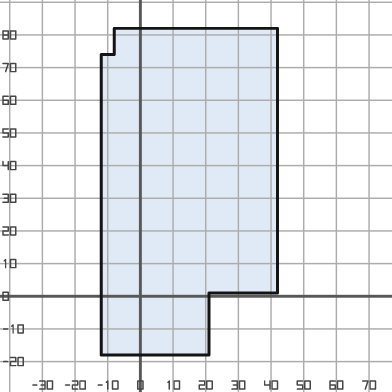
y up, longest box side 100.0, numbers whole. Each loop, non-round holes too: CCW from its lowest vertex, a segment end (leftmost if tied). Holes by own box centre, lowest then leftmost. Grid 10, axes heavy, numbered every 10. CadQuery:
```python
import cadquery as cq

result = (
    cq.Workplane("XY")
    .moveTo(-12.0, -18.0)
    .lineTo(21.0, -18.0)
    .lineTo(21.0, 1.0)
    .lineTo(42.0, 1.0)
    .lineTo(42.0, 82.0)
    .lineTo(-8.0, 82.0)
    .lineTo(-8.0, 74.0)
    .lineTo(-12.0, 74.0)
    .close()
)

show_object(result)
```